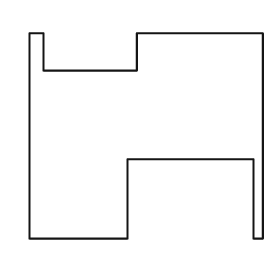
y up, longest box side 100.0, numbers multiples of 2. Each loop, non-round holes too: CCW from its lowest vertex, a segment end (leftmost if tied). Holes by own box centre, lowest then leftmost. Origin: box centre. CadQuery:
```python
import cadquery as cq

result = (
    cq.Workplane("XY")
    .moveTo(-50.0, -44.0)
    .lineTo(-8.0, -44.0)
    .lineTo(-8.0, -10.0)
    .lineTo(46.0, -10.0)
    .lineTo(46.0, -44.0)
    .lineTo(50.0, -44.0)
    .lineTo(50.0, 44.0)
    .lineTo(-4.0, 44.0)
    .lineTo(-4.0, 28.0)
    .lineTo(-44.0, 28.0)
    .lineTo(-44.0, 44.0)
    .lineTo(-50.0, 44.0)
    .close()
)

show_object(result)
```